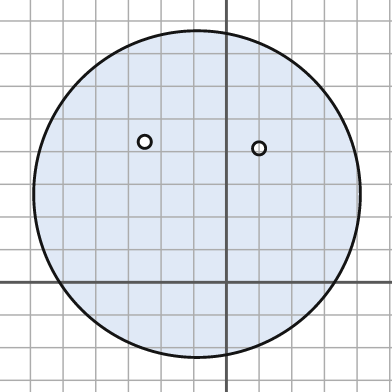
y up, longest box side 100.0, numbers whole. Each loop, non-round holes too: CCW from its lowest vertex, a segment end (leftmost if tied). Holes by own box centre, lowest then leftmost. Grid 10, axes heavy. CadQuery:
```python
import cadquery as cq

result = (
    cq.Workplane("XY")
    .moveTo(-9.0, 27.0)
    .circle(50.0)
    .moveTo(10.0, 41.0)
    .circle(2.0)
    .moveTo(-25.0, 43.0)
    .circle(2.0)
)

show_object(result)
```